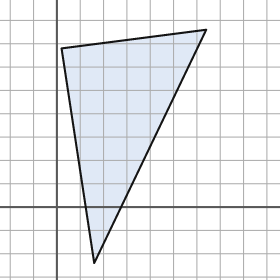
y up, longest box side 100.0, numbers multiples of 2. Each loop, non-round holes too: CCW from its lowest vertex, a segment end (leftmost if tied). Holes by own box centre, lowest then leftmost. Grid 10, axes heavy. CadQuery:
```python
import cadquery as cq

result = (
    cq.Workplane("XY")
    .moveTo(16.0, -24.0)
    .lineTo(64.0, 76.0)
    .lineTo(2.0, 68.0)
    .close()
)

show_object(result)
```